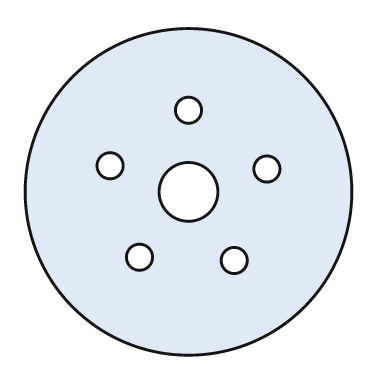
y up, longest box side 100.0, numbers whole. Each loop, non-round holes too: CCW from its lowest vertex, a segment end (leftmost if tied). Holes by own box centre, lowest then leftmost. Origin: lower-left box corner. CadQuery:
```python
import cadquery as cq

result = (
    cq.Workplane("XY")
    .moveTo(50.0, 50.0)
    .circle(50.0)
    .moveTo(64.0, 29.0)
    .circle(4.0)
    .moveTo(35.0, 30.0)
    .circle(4.0)
    .moveTo(50.0, 50.0)
    .circle(9.0)
    .moveTo(74.0, 57.0)
    .circle(4.0)
    .moveTo(26.0, 58.0)
    .circle(4.0)
    .moveTo(50.0, 75.0)
    .circle(4.0)
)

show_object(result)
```